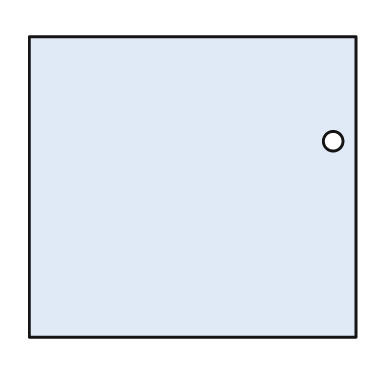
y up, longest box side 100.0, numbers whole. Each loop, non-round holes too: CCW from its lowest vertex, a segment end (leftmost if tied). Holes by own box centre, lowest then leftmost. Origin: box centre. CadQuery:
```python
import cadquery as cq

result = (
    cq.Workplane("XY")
    .moveTo(-50.0, -46.0)
    .lineTo(50.0, -46.0)
    .lineTo(50.0, 46.0)
    .lineTo(-50.0, 46.0)
    .close()
    .moveTo(43.0, 14.0)
    .circle(3.0)
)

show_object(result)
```